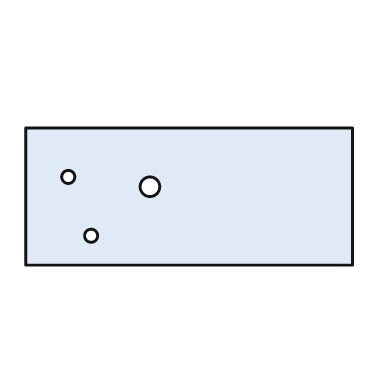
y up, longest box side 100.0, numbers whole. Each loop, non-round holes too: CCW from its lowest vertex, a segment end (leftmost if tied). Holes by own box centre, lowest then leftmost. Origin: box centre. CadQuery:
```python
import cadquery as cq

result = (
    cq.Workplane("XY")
    .moveTo(-50.0, -21.0)
    .lineTo(50.0, -21.0)
    .lineTo(50.0, 21.0)
    .lineTo(-50.0, 21.0)
    .close()
    .moveTo(-30.0, -12.0)
    .circle(2.0)
    .moveTo(-12.0, 3.0)
    .circle(3.0)
    .moveTo(-37.0, 6.0)
    .circle(2.0)
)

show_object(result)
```